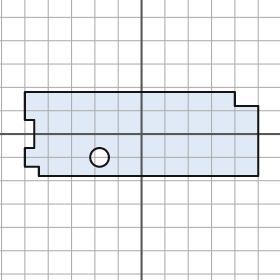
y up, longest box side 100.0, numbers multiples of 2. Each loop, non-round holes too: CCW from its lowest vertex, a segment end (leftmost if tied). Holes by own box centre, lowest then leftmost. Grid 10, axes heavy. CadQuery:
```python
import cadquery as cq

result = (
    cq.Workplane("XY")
    .moveTo(-44.0, -18.0)
    .lineTo(50.0, -18.0)
    .lineTo(50.0, 12.0)
    .lineTo(40.0, 12.0)
    .lineTo(40.0, 18.0)
    .lineTo(-50.0, 18.0)
    .lineTo(-50.0, 6.0)
    .lineTo(-46.0, 6.0)
    .lineTo(-46.0, -6.0)
    .lineTo(-50.0, -6.0)
    .lineTo(-50.0, -14.0)
    .lineTo(-44.0, -14.0)
    .close()
    .moveTo(-18.0, -10.0)
    .circle(4.0)
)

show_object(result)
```